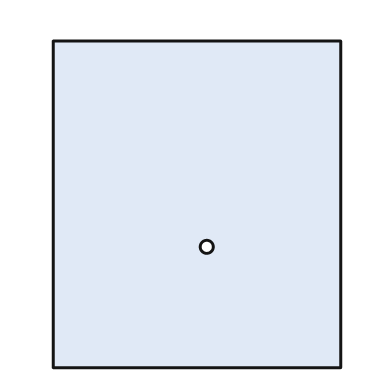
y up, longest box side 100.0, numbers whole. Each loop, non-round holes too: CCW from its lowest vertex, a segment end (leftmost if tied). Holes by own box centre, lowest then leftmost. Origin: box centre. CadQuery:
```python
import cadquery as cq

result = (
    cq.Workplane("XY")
    .moveTo(-44.0, -50.0)
    .lineTo(44.0, -50.0)
    .lineTo(44.0, 50.0)
    .lineTo(-44.0, 50.0)
    .close()
    .moveTo(3.0, -13.0)
    .circle(2.0)
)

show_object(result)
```